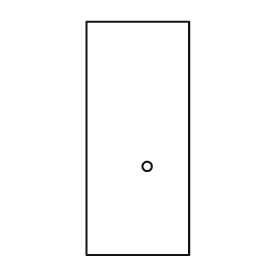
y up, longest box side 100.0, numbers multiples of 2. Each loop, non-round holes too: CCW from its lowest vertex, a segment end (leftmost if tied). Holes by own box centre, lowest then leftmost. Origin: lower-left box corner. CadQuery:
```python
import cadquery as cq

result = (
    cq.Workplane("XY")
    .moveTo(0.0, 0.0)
    .lineTo(44.0, 0.0)
    .lineTo(44.0, 100.0)
    .lineTo(0.0, 100.0)
    .close()
    .moveTo(26.0, 38.0)
    .circle(2.0)
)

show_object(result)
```